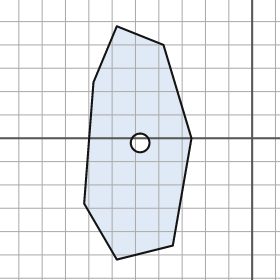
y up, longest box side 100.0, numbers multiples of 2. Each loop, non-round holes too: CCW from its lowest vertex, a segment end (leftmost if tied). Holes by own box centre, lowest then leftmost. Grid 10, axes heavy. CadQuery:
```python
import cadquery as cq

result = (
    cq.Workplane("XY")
    .moveTo(-58.0, -52.0)
    .lineTo(-34.0, -46.0)
    .lineTo(-26.0, 0.0)
    .lineTo(-38.0, 40.0)
    .lineTo(-58.0, 48.0)
    .lineTo(-68.0, 24.0)
    .lineTo(-72.0, -28.0)
    .close()
    .moveTo(-48.0, -2.0)
    .circle(4.0)
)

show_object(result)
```